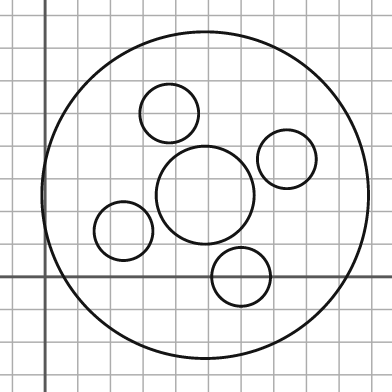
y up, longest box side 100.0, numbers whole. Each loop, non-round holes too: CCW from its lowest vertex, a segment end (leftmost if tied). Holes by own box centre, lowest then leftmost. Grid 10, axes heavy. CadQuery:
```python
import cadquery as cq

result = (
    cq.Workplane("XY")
    .moveTo(49.0, 25.0)
    .circle(50.0)
    .moveTo(60.0, 0.0)
    .circle(9.0)
    .moveTo(24.0, 14.0)
    .circle(9.0)
    .moveTo(49.0, 25.0)
    .circle(15.0)
    .moveTo(74.0, 36.0)
    .circle(9.0)
    .moveTo(38.0, 50.0)
    .circle(9.0)
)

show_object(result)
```